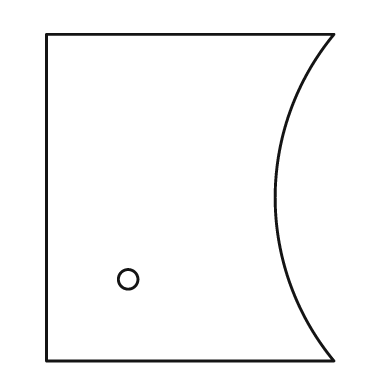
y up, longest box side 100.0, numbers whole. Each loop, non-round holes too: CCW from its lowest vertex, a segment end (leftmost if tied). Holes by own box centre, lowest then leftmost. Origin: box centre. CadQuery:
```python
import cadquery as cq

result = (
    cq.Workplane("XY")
    .moveTo(-44.0, -50.0)
    .lineTo(44.0, -50.0)
    .threePointArc((26.0, 0.0), (44.0, 50.0))
    .lineTo(-44.0, 50.0)
    .close()
    .moveTo(-19.0, -25.0)
    .circle(3.0)
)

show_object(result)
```